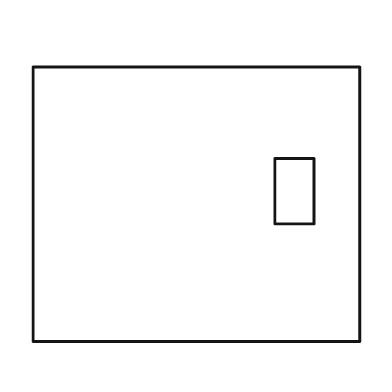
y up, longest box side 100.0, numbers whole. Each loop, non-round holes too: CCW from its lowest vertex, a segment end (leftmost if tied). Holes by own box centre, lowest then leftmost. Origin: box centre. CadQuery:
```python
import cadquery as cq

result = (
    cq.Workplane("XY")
    .moveTo(-50.0, -42.0)
    .lineTo(50.0, -42.0)
    .lineTo(50.0, 42.0)
    .lineTo(-50.0, 42.0)
    .close()
    .moveTo(24.0, -6.0)
    .lineTo(36.0, -6.0)
    .lineTo(36.0, 14.0)
    .lineTo(24.0, 14.0)
    .close()
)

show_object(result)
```